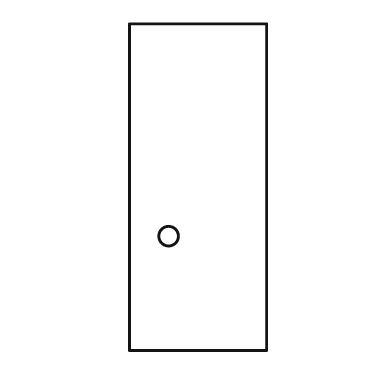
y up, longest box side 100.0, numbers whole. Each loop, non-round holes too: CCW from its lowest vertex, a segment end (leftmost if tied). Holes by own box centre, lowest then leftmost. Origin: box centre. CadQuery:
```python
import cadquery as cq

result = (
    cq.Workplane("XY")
    .moveTo(-21.0, -50.0)
    .lineTo(21.0, -50.0)
    .lineTo(21.0, 50.0)
    .lineTo(-21.0, 50.0)
    .close()
    .moveTo(-9.0, -15.0)
    .circle(3.0)
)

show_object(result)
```